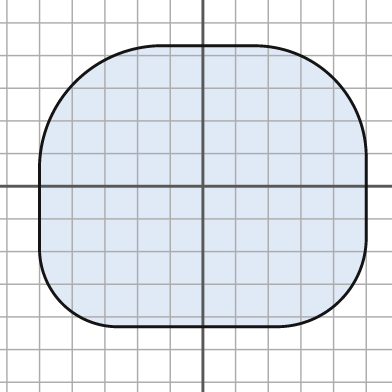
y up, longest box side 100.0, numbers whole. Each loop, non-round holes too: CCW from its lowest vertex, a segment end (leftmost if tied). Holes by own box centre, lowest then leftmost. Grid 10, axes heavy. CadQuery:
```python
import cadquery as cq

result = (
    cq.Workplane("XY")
    .moveTo(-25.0, -43.0)
    .lineTo(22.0, -43.0)
    .threePointArc((42.0, -35.0), (50.0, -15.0))
    .lineTo(50.0, 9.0)
    .threePointArc((40.0, 33.0), (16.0, 43.0))
    .lineTo(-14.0, 43.0)
    .threePointArc((-39.0, 32.0), (-50.0, 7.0))
    .lineTo(-50.0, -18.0)
    .threePointArc((-43.0, -36.0), (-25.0, -43.0))
    .close()
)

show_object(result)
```